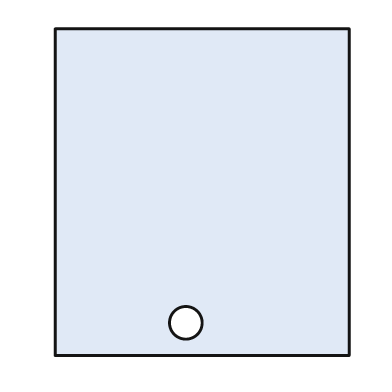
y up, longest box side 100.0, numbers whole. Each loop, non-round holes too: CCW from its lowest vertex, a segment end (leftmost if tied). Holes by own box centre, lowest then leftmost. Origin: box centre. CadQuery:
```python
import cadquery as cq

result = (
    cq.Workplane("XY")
    .moveTo(-45.0, -50.0)
    .lineTo(45.0, -50.0)
    .lineTo(45.0, 50.0)
    .lineTo(-45.0, 50.0)
    .close()
    .moveTo(-5.0, -40.0)
    .circle(5.0)
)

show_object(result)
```